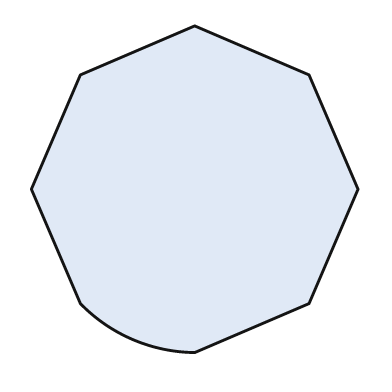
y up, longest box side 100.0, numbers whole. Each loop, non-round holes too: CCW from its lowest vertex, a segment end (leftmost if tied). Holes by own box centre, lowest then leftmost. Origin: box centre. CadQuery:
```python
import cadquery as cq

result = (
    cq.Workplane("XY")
    .moveTo(0.0, -50.0)
    .lineTo(35.0, -35.0)
    .lineTo(50.0, 0.0)
    .lineTo(35.0, 35.0)
    .lineTo(0.0, 50.0)
    .lineTo(-35.0, 35.0)
    .lineTo(-50.0, 0.0)
    .lineTo(-35.0, -35.0)
    .threePointArc((-19.0, -46.0), (0.0, -50.0))
    .close()
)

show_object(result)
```